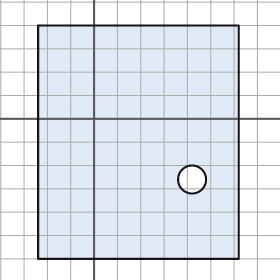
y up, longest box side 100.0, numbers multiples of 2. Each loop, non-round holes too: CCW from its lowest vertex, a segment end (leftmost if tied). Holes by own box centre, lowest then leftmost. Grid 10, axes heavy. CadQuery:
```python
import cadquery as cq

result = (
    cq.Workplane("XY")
    .moveTo(-24.0, -60.0)
    .lineTo(62.0, -60.0)
    .lineTo(62.0, 40.0)
    .lineTo(-24.0, 40.0)
    .close()
    .moveTo(42.0, -26.0)
    .circle(6.0)
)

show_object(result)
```